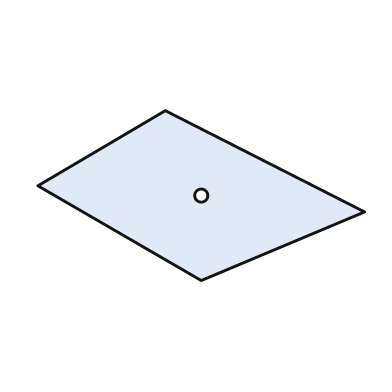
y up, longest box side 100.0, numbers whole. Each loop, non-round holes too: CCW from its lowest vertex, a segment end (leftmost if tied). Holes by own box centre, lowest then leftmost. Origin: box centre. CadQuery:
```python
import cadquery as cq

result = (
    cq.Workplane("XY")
    .moveTo(0.0, -26.0)
    .lineTo(50.0, -5.0)
    .lineTo(-11.0, 26.0)
    .lineTo(-50.0, 3.0)
    .close()
    .moveTo(0.0, 0.0)
    .circle(2.0)
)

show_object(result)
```